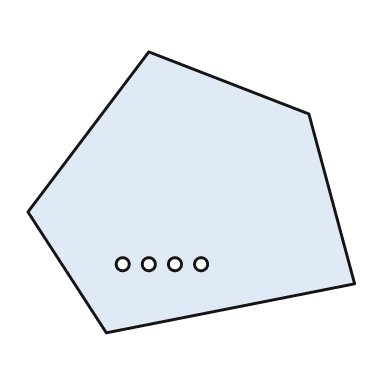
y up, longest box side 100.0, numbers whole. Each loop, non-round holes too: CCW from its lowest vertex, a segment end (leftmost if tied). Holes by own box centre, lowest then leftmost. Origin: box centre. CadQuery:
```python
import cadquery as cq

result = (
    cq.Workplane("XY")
    .moveTo(-26.0, -43.0)
    .lineTo(50.0, -28.0)
    .lineTo(36.0, 24.0)
    .lineTo(-13.0, 43.0)
    .lineTo(-50.0, -6.0)
    .close()
    .moveTo(-21.0, -22.0)
    .circle(2.0)
    .moveTo(-13.0, -22.0)
    .circle(2.0)
    .moveTo(-5.0, -22.0)
    .circle(2.0)
    .moveTo(3.0, -22.0)
    .circle(2.0)
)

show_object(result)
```